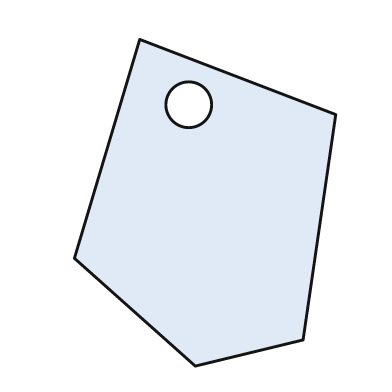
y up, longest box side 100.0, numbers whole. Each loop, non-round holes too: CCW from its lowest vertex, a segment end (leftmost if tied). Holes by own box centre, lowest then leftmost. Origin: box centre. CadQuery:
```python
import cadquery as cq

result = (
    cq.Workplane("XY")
    .moveTo(-3.0, -50.0)
    .lineTo(30.0, -42.0)
    .lineTo(40.0, 27.0)
    .lineTo(-20.0, 50.0)
    .lineTo(-40.0, -17.0)
    .close()
    .moveTo(-5.0, 30.0)
    .circle(7.0)
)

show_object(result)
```